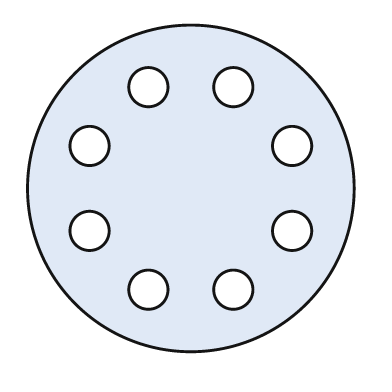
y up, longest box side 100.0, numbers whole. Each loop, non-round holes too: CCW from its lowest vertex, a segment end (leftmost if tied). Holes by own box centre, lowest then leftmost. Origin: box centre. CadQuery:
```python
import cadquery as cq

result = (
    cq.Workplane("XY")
    .moveTo(0.0, 0.0)
    .circle(50.0)
    .moveTo(-13.0, -31.0)
    .circle(6.0)
    .moveTo(13.0, -31.0)
    .circle(6.0)
    .moveTo(-31.0, -13.0)
    .circle(6.0)
    .moveTo(31.0, -13.0)
    .circle(6.0)
    .moveTo(-31.0, 13.0)
    .circle(6.0)
    .moveTo(31.0, 13.0)
    .circle(6.0)
    .moveTo(-13.0, 31.0)
    .circle(6.0)
    .moveTo(13.0, 31.0)
    .circle(6.0)
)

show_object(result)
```